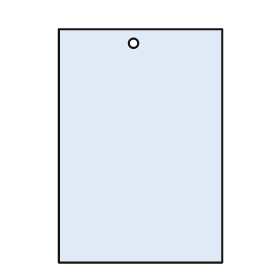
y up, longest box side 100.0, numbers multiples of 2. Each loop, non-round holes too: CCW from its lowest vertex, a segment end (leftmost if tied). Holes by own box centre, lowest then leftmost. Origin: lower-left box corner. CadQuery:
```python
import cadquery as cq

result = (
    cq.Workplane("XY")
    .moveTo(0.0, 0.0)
    .lineTo(70.0, 0.0)
    .lineTo(70.0, 100.0)
    .lineTo(0.0, 100.0)
    .close()
    .moveTo(32.0, 94.0)
    .circle(2.0)
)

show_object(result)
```